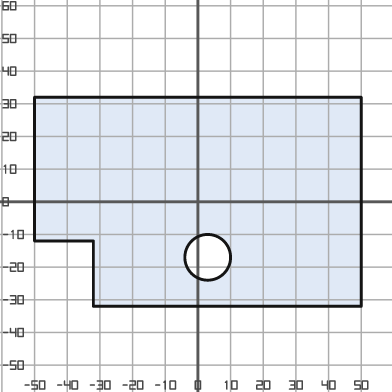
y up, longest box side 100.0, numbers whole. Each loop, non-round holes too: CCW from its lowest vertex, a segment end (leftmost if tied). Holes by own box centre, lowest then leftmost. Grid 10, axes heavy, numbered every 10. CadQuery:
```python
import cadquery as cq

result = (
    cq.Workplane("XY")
    .moveTo(-32.0, -32.0)
    .lineTo(50.0, -32.0)
    .lineTo(50.0, 32.0)
    .lineTo(-50.0, 32.0)
    .lineTo(-50.0, -12.0)
    .lineTo(-32.0, -12.0)
    .close()
    .moveTo(3.0, -17.0)
    .circle(7.0)
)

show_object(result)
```